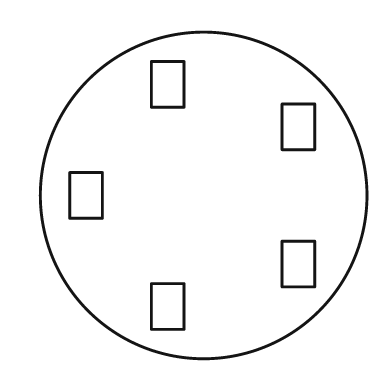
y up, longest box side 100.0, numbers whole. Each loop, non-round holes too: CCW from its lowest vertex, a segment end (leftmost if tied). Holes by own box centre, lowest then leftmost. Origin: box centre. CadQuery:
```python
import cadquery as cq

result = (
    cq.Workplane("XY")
    .moveTo(0.0, 0.0)
    .circle(50.0)
    .moveTo(-16.0, -41.0)
    .lineTo(-6.0, -41.0)
    .lineTo(-6.0, -27.0)
    .lineTo(-16.0, -27.0)
    .close()
    .moveTo(24.0, -28.0)
    .lineTo(34.0, -28.0)
    .lineTo(34.0, -14.0)
    .lineTo(24.0, -14.0)
    .close()
    .moveTo(-41.0, -7.0)
    .lineTo(-31.0, -7.0)
    .lineTo(-31.0, 7.0)
    .lineTo(-41.0, 7.0)
    .close()
    .moveTo(24.0, 14.0)
    .lineTo(34.0, 14.0)
    .lineTo(34.0, 28.0)
    .lineTo(24.0, 28.0)
    .close()
    .moveTo(-16.0, 27.0)
    .lineTo(-6.0, 27.0)
    .lineTo(-6.0, 41.0)
    .lineTo(-16.0, 41.0)
    .close()
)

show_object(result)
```